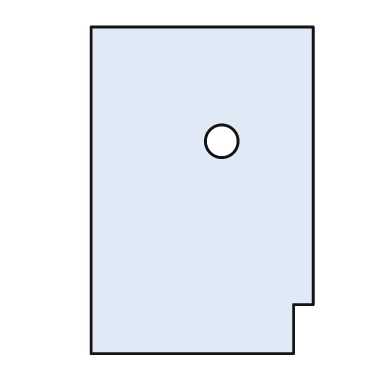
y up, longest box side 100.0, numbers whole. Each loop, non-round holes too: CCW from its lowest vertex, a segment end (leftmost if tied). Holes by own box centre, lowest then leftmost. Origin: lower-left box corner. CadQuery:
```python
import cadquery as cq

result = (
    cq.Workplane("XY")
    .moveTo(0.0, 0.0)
    .lineTo(62.0, 0.0)
    .lineTo(62.0, 15.0)
    .lineTo(68.0, 15.0)
    .lineTo(68.0, 100.0)
    .lineTo(0.0, 100.0)
    .close()
    .moveTo(40.0, 65.0)
    .circle(5.0)
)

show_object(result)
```